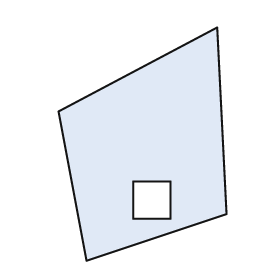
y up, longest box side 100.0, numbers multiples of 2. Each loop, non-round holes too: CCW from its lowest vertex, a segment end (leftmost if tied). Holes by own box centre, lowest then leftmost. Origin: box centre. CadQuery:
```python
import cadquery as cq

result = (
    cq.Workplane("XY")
    .moveTo(-24.0, -50.0)
    .lineTo(36.0, -30.0)
    .lineTo(32.0, 50.0)
    .lineTo(-36.0, 14.0)
    .close()
    .moveTo(-4.0, -32.0)
    .lineTo(12.0, -32.0)
    .lineTo(12.0, -16.0)
    .lineTo(-4.0, -16.0)
    .close()
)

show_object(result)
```